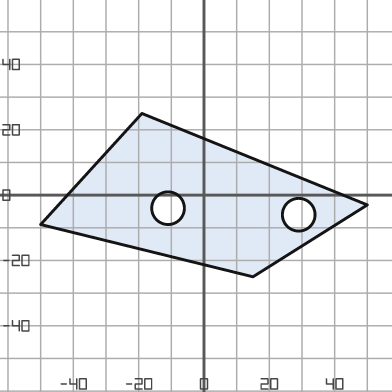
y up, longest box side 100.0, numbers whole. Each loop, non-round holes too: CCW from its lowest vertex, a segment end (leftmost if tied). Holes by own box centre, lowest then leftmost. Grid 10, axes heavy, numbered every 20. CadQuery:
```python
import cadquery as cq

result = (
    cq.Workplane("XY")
    .moveTo(15.0, -25.0)
    .lineTo(50.0, -3.0)
    .lineTo(-19.0, 25.0)
    .lineTo(-50.0, -9.0)
    .close()
    .moveTo(29.0, -6.0)
    .circle(5.0)
    .moveTo(-11.0, -4.0)
    .circle(5.0)
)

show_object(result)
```